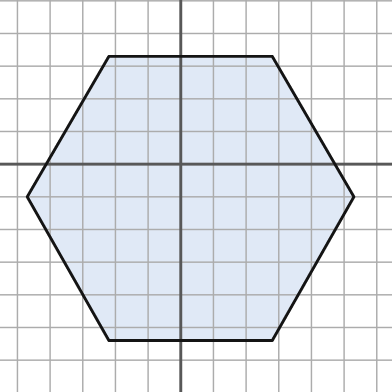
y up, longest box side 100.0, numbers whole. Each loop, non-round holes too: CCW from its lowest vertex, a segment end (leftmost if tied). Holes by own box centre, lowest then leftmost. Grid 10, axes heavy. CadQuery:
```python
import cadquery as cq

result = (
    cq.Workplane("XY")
    .moveTo(-22.0, -54.0)
    .lineTo(28.0, -54.0)
    .lineTo(53.0, -10.0)
    .lineTo(28.0, 33.0)
    .lineTo(-22.0, 33.0)
    .lineTo(-47.0, -10.0)
    .close()
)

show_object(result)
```